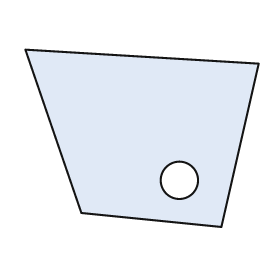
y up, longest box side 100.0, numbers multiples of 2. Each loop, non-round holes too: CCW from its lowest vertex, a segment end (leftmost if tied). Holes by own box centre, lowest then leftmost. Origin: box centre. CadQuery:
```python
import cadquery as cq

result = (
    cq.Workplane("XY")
    .moveTo(34.0, -38.0)
    .lineTo(50.0, 32.0)
    .lineTo(-50.0, 38.0)
    .lineTo(-26.0, -32.0)
    .close()
    .moveTo(16.0, -18.0)
    .circle(8.0)
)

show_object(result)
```